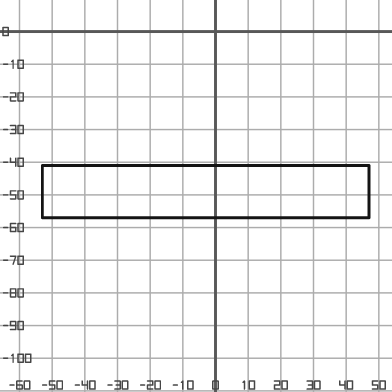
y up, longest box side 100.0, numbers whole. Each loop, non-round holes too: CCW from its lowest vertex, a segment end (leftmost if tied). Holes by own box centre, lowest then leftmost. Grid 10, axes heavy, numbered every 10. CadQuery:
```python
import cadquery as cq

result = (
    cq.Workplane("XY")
    .moveTo(-53.0, -57.0)
    .lineTo(47.0, -57.0)
    .lineTo(47.0, -41.0)
    .lineTo(-53.0, -41.0)
    .close()
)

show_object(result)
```